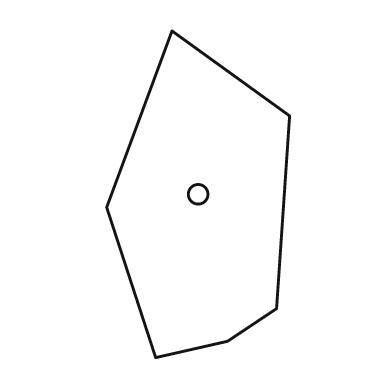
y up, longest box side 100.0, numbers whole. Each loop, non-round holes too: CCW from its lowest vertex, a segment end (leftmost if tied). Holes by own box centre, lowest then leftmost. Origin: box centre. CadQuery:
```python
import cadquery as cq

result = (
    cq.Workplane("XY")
    .moveTo(-13.0, -50.0)
    .lineTo(9.0, -45.0)
    .lineTo(24.0, -35.0)
    .lineTo(28.0, 24.0)
    .lineTo(-8.0, 50.0)
    .lineTo(-28.0, -4.0)
    .close()
    .moveTo(0.0, 0.0)
    .circle(3.0)
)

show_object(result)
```